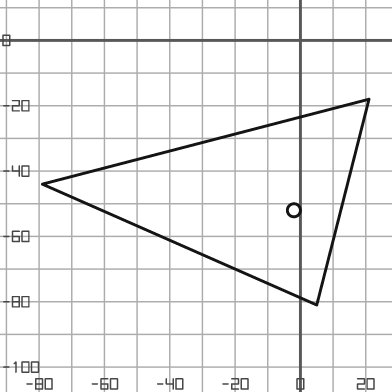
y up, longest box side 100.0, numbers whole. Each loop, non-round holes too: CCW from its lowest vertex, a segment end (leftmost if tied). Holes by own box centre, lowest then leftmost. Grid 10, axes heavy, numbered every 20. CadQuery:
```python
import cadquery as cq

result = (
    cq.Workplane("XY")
    .moveTo(5.0, -81.0)
    .lineTo(21.0, -18.0)
    .lineTo(-79.0, -44.0)
    .close()
    .moveTo(-2.0, -52.0)
    .circle(2.0)
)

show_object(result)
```